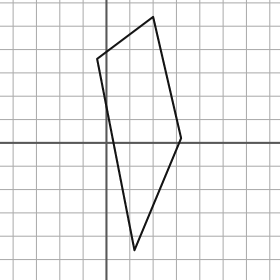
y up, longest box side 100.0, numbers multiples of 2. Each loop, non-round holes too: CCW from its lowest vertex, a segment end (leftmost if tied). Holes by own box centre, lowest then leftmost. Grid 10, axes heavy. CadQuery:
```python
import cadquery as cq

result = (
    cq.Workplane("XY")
    .moveTo(12.0, -46.0)
    .lineTo(32.0, 2.0)
    .lineTo(20.0, 54.0)
    .lineTo(-4.0, 36.0)
    .close()
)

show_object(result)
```